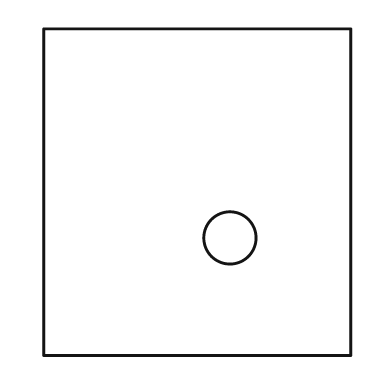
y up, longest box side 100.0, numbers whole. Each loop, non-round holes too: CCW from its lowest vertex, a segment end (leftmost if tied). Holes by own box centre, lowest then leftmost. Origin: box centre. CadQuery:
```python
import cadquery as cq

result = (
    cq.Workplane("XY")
    .moveTo(-47.0, -50.0)
    .lineTo(47.0, -50.0)
    .lineTo(47.0, 50.0)
    .lineTo(-47.0, 50.0)
    .close()
    .moveTo(10.0, -14.0)
    .circle(8.0)
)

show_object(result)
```